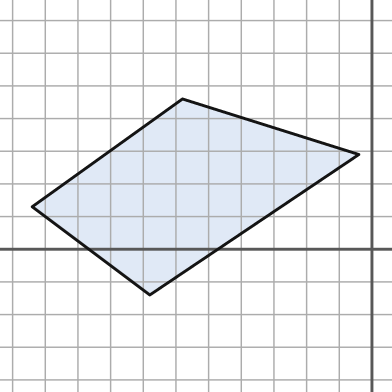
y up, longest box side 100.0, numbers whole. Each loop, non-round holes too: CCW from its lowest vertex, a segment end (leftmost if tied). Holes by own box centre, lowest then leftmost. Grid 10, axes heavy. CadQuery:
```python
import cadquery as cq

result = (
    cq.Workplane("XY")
    .moveTo(-68.0, -14.0)
    .lineTo(-4.0, 29.0)
    .lineTo(-58.0, 46.0)
    .lineTo(-104.0, 13.0)
    .close()
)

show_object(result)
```